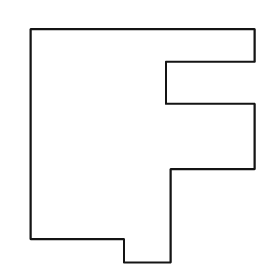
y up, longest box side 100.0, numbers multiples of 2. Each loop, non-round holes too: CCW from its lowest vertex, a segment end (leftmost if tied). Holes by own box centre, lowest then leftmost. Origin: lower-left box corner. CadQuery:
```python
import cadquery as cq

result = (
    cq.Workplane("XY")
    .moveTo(40.0, 0.0)
    .lineTo(60.0, 0.0)
    .lineTo(60.0, 40.0)
    .lineTo(96.0, 40.0)
    .lineTo(96.0, 68.0)
    .lineTo(58.0, 68.0)
    .lineTo(58.0, 86.0)
    .lineTo(96.0, 86.0)
    .lineTo(96.0, 100.0)
    .lineTo(0.0, 100.0)
    .lineTo(0.0, 10.0)
    .lineTo(40.0, 10.0)
    .close()
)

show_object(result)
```